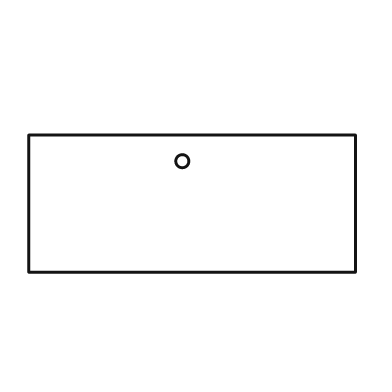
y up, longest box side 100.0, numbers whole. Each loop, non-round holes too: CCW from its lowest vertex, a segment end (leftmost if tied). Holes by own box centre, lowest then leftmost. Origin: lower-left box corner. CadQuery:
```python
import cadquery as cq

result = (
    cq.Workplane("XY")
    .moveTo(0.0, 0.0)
    .lineTo(100.0, 0.0)
    .lineTo(100.0, 42.0)
    .lineTo(0.0, 42.0)
    .close()
    .moveTo(47.0, 34.0)
    .circle(2.0)
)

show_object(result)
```